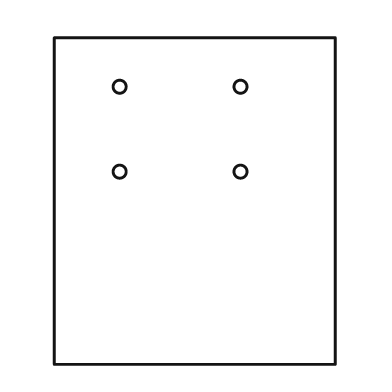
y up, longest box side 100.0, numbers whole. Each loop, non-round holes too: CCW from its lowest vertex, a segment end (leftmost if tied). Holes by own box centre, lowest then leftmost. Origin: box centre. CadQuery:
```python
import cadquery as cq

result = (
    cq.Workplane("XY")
    .moveTo(-43.0, -50.0)
    .lineTo(43.0, -50.0)
    .lineTo(43.0, 50.0)
    .lineTo(-43.0, 50.0)
    .close()
    .moveTo(-23.0, 9.0)
    .circle(2.0)
    .moveTo(14.0, 9.0)
    .circle(2.0)
    .moveTo(-23.0, 35.0)
    .circle(2.0)
    .moveTo(14.0, 35.0)
    .circle(2.0)
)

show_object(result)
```